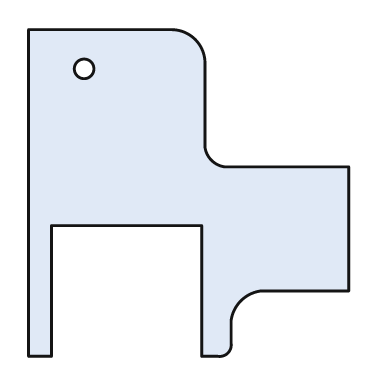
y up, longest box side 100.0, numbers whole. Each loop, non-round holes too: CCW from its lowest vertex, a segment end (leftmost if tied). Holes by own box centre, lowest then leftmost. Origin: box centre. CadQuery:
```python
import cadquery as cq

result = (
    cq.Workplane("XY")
    .moveTo(-49.0, -50.0)
    .lineTo(-42.0, -50.0)
    .lineTo(-42.0, -10.0)
    .lineTo(4.0, -10.0)
    .lineTo(4.0, -50.0)
    .lineTo(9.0, -50.0)
    .threePointArc((12.0, -49.0), (13.0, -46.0))
    .lineTo(13.0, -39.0)
    .threePointArc((16.0, -33.0), (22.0, -30.0))
    .lineTo(49.0, -30.0)
    .lineTo(49.0, 8.0)
    .lineTo(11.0, 8.0)
    .threePointArc((7.0, 10.0), (5.0, 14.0))
    .lineTo(5.0, 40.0)
    .threePointArc((2.0, 47.0), (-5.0, 50.0))
    .lineTo(-49.0, 50.0)
    .close()
    .moveTo(-32.0, 38.0)
    .circle(3.0)
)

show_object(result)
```